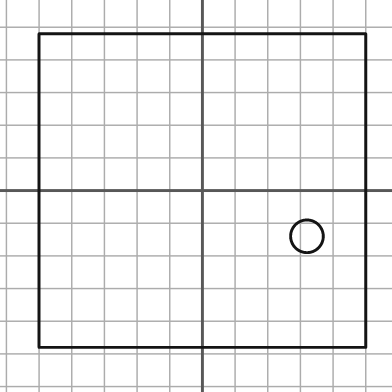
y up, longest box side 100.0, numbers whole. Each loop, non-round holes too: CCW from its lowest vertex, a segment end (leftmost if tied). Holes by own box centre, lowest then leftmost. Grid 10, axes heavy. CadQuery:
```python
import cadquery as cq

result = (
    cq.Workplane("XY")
    .moveTo(-50.0, -48.0)
    .lineTo(50.0, -48.0)
    .lineTo(50.0, 48.0)
    .lineTo(-50.0, 48.0)
    .close()
    .moveTo(32.0, -14.0)
    .circle(5.0)
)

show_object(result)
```